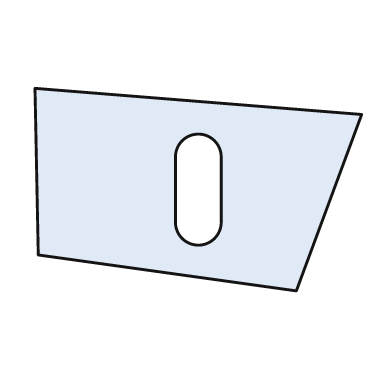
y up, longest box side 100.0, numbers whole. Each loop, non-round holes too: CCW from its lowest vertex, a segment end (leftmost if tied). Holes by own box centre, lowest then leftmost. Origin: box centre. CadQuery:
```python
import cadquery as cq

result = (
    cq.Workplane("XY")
    .moveTo(30.0, -31.0)
    .lineTo(50.0, 23.0)
    .lineTo(-50.0, 31.0)
    .lineTo(-49.0, -20.0)
    .close()
    .moveTo(-7.0, -10.0)
    .threePointArc((0.0, -17.0), (7.0, -10.0))
    .lineTo(7.0, 10.0)
    .threePointArc((0.0, 17.0), (-7.0, 10.0))
    .close()
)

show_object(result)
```